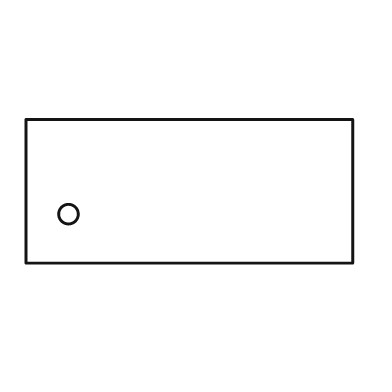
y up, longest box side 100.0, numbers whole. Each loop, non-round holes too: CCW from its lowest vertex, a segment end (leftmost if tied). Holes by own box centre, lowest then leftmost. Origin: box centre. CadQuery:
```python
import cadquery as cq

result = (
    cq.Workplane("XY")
    .moveTo(-50.0, -22.0)
    .lineTo(50.0, -22.0)
    .lineTo(50.0, 22.0)
    .lineTo(-50.0, 22.0)
    .close()
    .moveTo(-37.0, -7.0)
    .circle(3.0)
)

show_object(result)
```